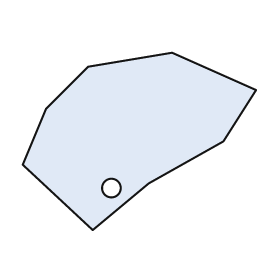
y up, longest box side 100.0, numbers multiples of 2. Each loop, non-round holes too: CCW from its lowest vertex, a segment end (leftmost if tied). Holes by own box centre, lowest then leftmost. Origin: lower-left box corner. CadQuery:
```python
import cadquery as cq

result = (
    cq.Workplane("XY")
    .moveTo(30.0, 0.0)
    .lineTo(54.0, 20.0)
    .lineTo(86.0, 38.0)
    .lineTo(100.0, 60.0)
    .lineTo(64.0, 76.0)
    .lineTo(28.0, 70.0)
    .lineTo(10.0, 52.0)
    .lineTo(0.0, 28.0)
    .close()
    .moveTo(38.0, 18.0)
    .circle(4.0)
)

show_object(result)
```